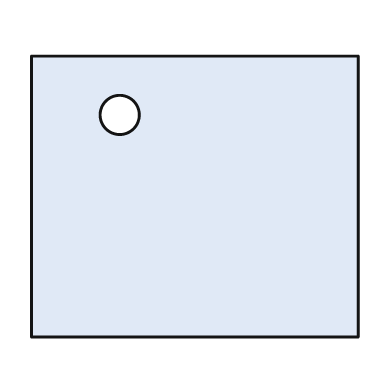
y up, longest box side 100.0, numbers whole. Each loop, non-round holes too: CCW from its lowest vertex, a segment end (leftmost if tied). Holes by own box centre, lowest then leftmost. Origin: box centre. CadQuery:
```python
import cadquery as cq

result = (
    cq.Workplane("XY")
    .moveTo(-50.0, -43.0)
    .lineTo(50.0, -43.0)
    .lineTo(50.0, 43.0)
    .lineTo(-50.0, 43.0)
    .close()
    .moveTo(-23.0, 25.0)
    .circle(6.0)
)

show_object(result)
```